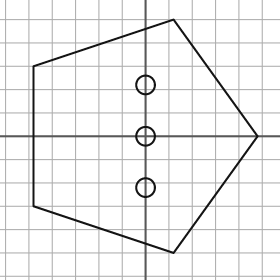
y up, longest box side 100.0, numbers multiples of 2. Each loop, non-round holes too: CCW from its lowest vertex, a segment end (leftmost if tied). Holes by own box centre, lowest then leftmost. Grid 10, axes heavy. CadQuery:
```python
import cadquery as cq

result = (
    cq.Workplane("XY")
    .moveTo(12.0, -50.0)
    .lineTo(48.0, 0.0)
    .lineTo(12.0, 50.0)
    .lineTo(-48.0, 30.0)
    .lineTo(-48.0, -30.0)
    .close()
    .moveTo(0.0, -22.0)
    .circle(4.0)
    .moveTo(0.0, 0.0)
    .circle(4.0)
    .moveTo(0.0, 22.0)
    .circle(4.0)
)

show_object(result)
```